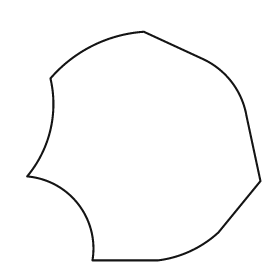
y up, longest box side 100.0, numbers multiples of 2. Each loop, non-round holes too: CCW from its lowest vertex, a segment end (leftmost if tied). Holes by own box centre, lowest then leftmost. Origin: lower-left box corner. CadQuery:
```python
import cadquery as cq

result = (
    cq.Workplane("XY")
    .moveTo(28.0, 0.0)
    .lineTo(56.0, 0.0)
    .threePointArc((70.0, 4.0), (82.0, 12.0))
    .lineTo(100.0, 34.0)
    .lineTo(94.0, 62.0)
    .threePointArc((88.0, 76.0), (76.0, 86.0))
    .lineTo(50.0, 98.0)
    .threePointArc((28.0, 92.0), (10.0, 78.0))
    .threePointArc((10.0, 56.0), (0.0, 36.0))
    .threePointArc((22.0, 24.0), (28.0, 0.0))
    .close()
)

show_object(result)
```